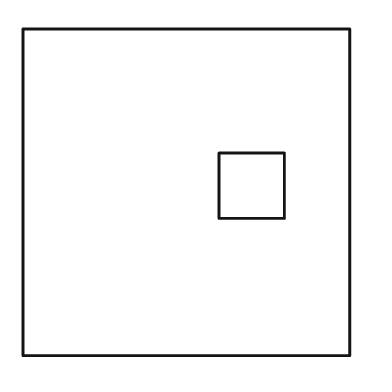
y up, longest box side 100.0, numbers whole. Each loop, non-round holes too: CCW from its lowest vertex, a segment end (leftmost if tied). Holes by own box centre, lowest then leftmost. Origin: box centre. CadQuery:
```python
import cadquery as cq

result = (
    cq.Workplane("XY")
    .moveTo(-50.0, -50.0)
    .lineTo(50.0, -50.0)
    .lineTo(50.0, 50.0)
    .lineTo(-50.0, 50.0)
    .close()
    .moveTo(10.0, -8.0)
    .lineTo(30.0, -8.0)
    .lineTo(30.0, 12.0)
    .lineTo(10.0, 12.0)
    .close()
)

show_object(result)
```